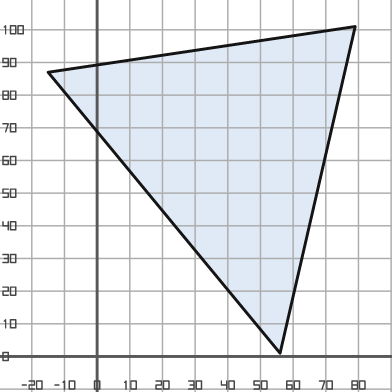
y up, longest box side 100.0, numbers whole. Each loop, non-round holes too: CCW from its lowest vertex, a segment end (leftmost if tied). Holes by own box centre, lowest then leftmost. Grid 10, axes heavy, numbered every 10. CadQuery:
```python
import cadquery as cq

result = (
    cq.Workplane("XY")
    .moveTo(56.0, 1.0)
    .lineTo(79.0, 101.0)
    .lineTo(-15.0, 87.0)
    .close()
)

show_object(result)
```